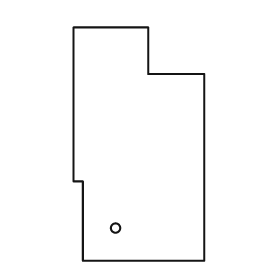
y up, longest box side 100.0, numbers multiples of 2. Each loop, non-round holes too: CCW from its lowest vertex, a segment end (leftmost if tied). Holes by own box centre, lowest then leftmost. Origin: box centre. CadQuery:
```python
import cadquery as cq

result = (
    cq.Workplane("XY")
    .moveTo(-24.0, -50.0)
    .lineTo(28.0, -50.0)
    .lineTo(28.0, 30.0)
    .lineTo(4.0, 30.0)
    .lineTo(4.0, 50.0)
    .lineTo(-28.0, 50.0)
    .lineTo(-28.0, -16.0)
    .lineTo(-24.0, -16.0)
    .close()
    .moveTo(-10.0, -36.0)
    .circle(2.0)
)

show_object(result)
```